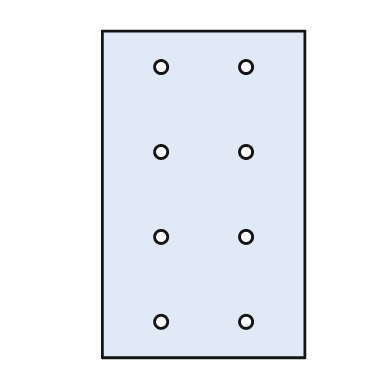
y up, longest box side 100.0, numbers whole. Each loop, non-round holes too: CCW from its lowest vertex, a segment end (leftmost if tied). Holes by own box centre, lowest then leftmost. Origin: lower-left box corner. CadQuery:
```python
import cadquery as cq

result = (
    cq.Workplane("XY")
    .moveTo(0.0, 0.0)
    .lineTo(62.0, 0.0)
    .lineTo(62.0, 100.0)
    .lineTo(0.0, 100.0)
    .close()
    .moveTo(18.0, 11.0)
    .circle(2.0)
    .moveTo(44.0, 11.0)
    .circle(2.0)
    .moveTo(18.0, 37.0)
    .circle(2.0)
    .moveTo(44.0, 37.0)
    .circle(2.0)
    .moveTo(18.0, 63.0)
    .circle(2.0)
    .moveTo(44.0, 63.0)
    .circle(2.0)
    .moveTo(18.0, 89.0)
    .circle(2.0)
    .moveTo(44.0, 89.0)
    .circle(2.0)
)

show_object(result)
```